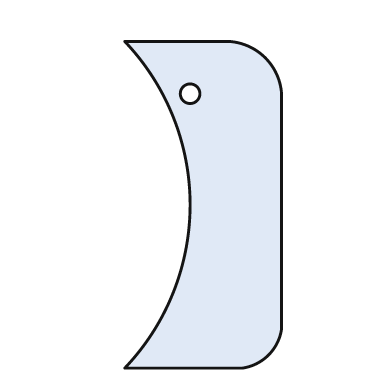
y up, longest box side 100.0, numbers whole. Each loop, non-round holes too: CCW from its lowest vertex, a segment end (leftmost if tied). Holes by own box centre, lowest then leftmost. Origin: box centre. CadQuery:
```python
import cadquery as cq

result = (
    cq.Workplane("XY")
    .moveTo(-24.0, -50.0)
    .lineTo(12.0, -50.0)
    .threePointArc((20.0, -46.0), (24.0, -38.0))
    .lineTo(24.0, 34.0)
    .threePointArc((19.0, 45.0), (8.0, 50.0))
    .lineTo(-24.0, 50.0)
    .threePointArc((-4.0, 0.0), (-24.0, -50.0))
    .close()
    .moveTo(-4.0, 34.0)
    .circle(3.0)
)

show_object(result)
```